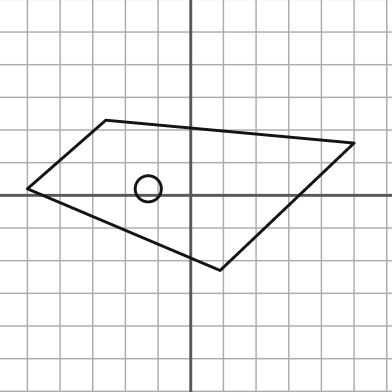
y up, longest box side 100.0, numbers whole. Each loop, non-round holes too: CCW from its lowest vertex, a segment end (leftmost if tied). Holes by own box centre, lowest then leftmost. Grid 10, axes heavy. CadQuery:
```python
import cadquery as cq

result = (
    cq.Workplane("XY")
    .moveTo(9.0, -23.0)
    .lineTo(50.0, 16.0)
    .lineTo(-26.0, 23.0)
    .lineTo(-50.0, 2.0)
    .close()
    .moveTo(-13.0, 2.0)
    .circle(4.0)
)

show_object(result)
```